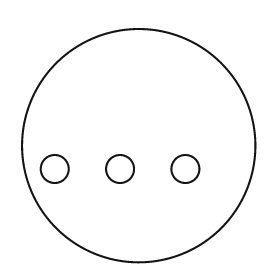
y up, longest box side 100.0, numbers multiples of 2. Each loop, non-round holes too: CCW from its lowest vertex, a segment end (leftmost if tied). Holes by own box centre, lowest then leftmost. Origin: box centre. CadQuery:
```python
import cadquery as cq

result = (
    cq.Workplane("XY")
    .moveTo(0.0, 0.0)
    .circle(50.0)
    .moveTo(-36.0, -10.0)
    .circle(6.0)
    .moveTo(-8.0, -10.0)
    .circle(6.0)
    .moveTo(20.0, -10.0)
    .circle(6.0)
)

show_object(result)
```